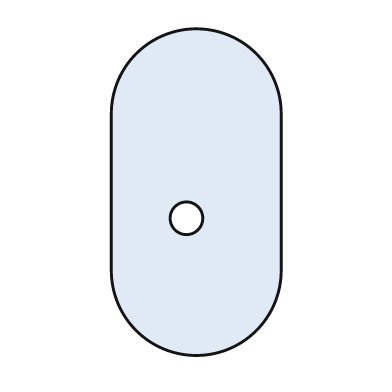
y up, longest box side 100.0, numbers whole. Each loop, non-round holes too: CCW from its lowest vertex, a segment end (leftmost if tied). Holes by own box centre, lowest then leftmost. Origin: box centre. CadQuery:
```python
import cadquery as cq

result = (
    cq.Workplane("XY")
    .moveTo(-26.0, -24.0)
    .threePointArc((0.0, -50.0), (26.0, -24.0))
    .lineTo(26.0, 24.0)
    .threePointArc((0.0, 50.0), (-26.0, 24.0))
    .close()
    .moveTo(-3.0, -8.0)
    .circle(5.0)
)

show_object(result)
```